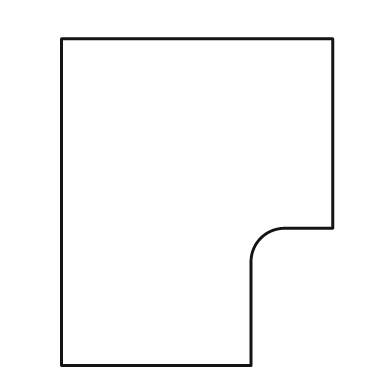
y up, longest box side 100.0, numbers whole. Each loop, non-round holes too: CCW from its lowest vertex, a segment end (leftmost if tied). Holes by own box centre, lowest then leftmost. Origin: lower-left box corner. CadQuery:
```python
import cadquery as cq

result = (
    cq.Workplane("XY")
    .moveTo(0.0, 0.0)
    .lineTo(58.0, 0.0)
    .lineTo(58.0, 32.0)
    .threePointArc((61.0, 39.0), (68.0, 42.0))
    .lineTo(83.0, 42.0)
    .lineTo(83.0, 100.0)
    .lineTo(0.0, 100.0)
    .close()
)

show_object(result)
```